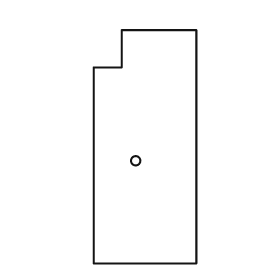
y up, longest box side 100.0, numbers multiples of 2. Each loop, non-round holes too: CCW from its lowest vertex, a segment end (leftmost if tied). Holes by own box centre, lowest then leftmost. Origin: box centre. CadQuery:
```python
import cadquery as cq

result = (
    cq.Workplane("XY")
    .moveTo(-22.0, -50.0)
    .lineTo(22.0, -50.0)
    .lineTo(22.0, 50.0)
    .lineTo(-10.0, 50.0)
    .lineTo(-10.0, 34.0)
    .lineTo(-22.0, 34.0)
    .close()
    .moveTo(-4.0, -6.0)
    .circle(2.0)
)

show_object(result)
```